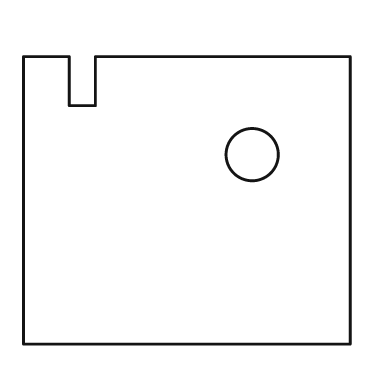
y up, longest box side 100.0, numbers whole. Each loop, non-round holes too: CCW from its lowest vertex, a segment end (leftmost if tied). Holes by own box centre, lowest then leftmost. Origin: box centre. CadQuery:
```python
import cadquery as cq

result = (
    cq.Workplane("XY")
    .moveTo(-50.0, -44.0)
    .lineTo(50.0, -44.0)
    .lineTo(50.0, 44.0)
    .lineTo(-28.0, 44.0)
    .lineTo(-28.0, 29.0)
    .lineTo(-36.0, 29.0)
    .lineTo(-36.0, 44.0)
    .lineTo(-50.0, 44.0)
    .close()
    .moveTo(20.0, 14.0)
    .circle(8.0)
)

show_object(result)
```